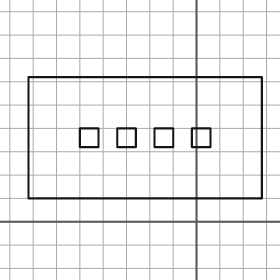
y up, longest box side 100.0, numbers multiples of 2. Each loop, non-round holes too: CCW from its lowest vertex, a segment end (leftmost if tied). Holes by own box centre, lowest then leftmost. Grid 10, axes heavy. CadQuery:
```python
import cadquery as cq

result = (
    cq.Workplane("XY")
    .moveTo(-72.0, 10.0)
    .lineTo(28.0, 10.0)
    .lineTo(28.0, 62.0)
    .lineTo(-72.0, 62.0)
    .close()
    .moveTo(-50.0, 32.0)
    .lineTo(-42.0, 32.0)
    .lineTo(-42.0, 40.0)
    .lineTo(-50.0, 40.0)
    .close()
    .moveTo(-34.0, 32.0)
    .lineTo(-26.0, 32.0)
    .lineTo(-26.0, 40.0)
    .lineTo(-34.0, 40.0)
    .close()
    .moveTo(-18.0, 32.0)
    .lineTo(-10.0, 32.0)
    .lineTo(-10.0, 40.0)
    .lineTo(-18.0, 40.0)
    .close()
    .moveTo(-2.0, 32.0)
    .lineTo(6.0, 32.0)
    .lineTo(6.0, 40.0)
    .lineTo(-2.0, 40.0)
    .close()
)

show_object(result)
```